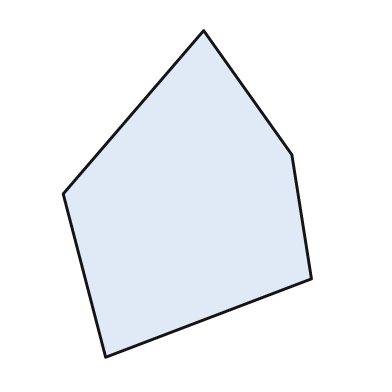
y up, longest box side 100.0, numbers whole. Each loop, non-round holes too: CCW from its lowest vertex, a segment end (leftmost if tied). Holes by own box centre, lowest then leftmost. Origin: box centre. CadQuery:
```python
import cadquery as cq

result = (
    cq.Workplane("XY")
    .moveTo(-25.0, -50.0)
    .lineTo(38.0, -26.0)
    .lineTo(32.0, 12.0)
    .lineTo(5.0, 50.0)
    .lineTo(-38.0, 0.0)
    .close()
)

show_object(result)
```